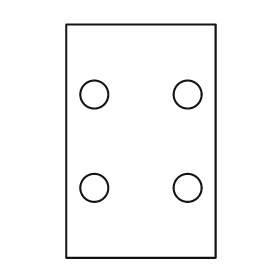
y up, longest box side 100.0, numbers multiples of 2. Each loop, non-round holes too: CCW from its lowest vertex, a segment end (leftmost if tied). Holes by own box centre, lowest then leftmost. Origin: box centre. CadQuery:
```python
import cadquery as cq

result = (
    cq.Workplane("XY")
    .moveTo(-32.0, -50.0)
    .lineTo(32.0, -50.0)
    .lineTo(32.0, 50.0)
    .lineTo(-32.0, 50.0)
    .close()
    .moveTo(-20.0, -20.0)
    .circle(6.0)
    .moveTo(20.0, -20.0)
    .circle(6.0)
    .moveTo(-20.0, 20.0)
    .circle(6.0)
    .moveTo(20.0, 20.0)
    .circle(6.0)
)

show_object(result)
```